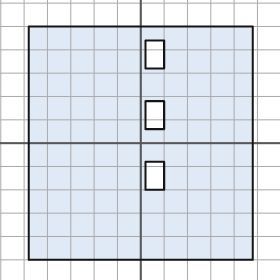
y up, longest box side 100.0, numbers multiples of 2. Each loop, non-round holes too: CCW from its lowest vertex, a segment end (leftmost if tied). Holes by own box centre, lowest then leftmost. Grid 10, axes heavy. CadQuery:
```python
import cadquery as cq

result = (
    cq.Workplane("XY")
    .moveTo(-48.0, -50.0)
    .lineTo(48.0, -50.0)
    .lineTo(48.0, 50.0)
    .lineTo(-48.0, 50.0)
    .close()
    .moveTo(2.0, -20.0)
    .lineTo(10.0, -20.0)
    .lineTo(10.0, -8.0)
    .lineTo(2.0, -8.0)
    .close()
    .moveTo(2.0, 6.0)
    .lineTo(10.0, 6.0)
    .lineTo(10.0, 18.0)
    .lineTo(2.0, 18.0)
    .close()
    .moveTo(2.0, 32.0)
    .lineTo(10.0, 32.0)
    .lineTo(10.0, 44.0)
    .lineTo(2.0, 44.0)
    .close()
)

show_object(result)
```